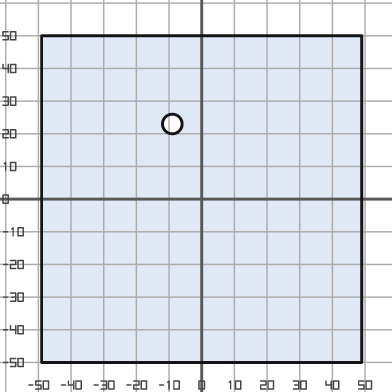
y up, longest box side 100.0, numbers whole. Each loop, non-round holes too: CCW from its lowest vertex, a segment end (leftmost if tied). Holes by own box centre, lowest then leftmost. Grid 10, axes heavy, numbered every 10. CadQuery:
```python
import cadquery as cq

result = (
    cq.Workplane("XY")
    .moveTo(-49.0, -50.0)
    .lineTo(49.0, -50.0)
    .lineTo(49.0, 50.0)
    .lineTo(-49.0, 50.0)
    .close()
    .moveTo(-9.0, 23.0)
    .circle(3.0)
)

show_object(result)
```